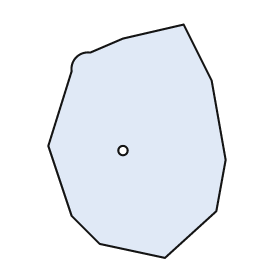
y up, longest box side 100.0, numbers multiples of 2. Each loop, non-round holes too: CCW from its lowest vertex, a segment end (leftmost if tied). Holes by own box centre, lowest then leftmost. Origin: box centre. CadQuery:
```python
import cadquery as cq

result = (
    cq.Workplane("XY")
    .moveTo(12.0, -50.0)
    .lineTo(34.0, -30.0)
    .lineTo(38.0, -8.0)
    .lineTo(32.0, 26.0)
    .lineTo(20.0, 50.0)
    .lineTo(-6.0, 44.0)
    .lineTo(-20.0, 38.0)
    .threePointArc((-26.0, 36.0), (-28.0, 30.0))
    .lineTo(-38.0, -2.0)
    .lineTo(-28.0, -32.0)
    .lineTo(-16.0, -44.0)
    .close()
    .moveTo(-6.0, -4.0)
    .circle(2.0)
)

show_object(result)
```